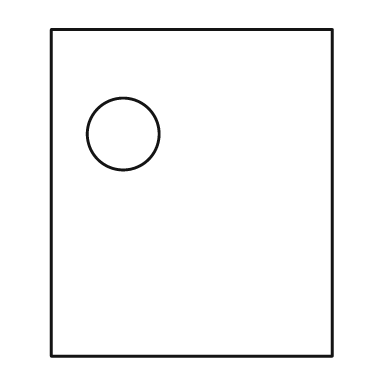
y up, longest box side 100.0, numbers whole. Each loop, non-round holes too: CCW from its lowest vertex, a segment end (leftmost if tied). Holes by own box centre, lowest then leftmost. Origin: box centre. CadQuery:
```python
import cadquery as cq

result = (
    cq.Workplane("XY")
    .moveTo(-43.0, -50.0)
    .lineTo(43.0, -50.0)
    .lineTo(43.0, 50.0)
    .lineTo(-43.0, 50.0)
    .close()
    .moveTo(-21.0, 18.0)
    .circle(11.0)
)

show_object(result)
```